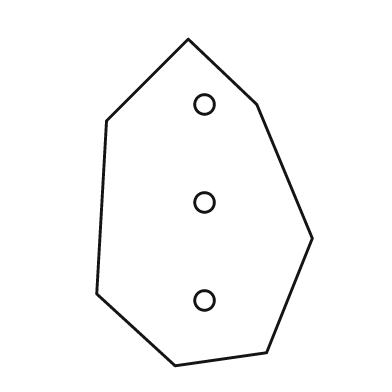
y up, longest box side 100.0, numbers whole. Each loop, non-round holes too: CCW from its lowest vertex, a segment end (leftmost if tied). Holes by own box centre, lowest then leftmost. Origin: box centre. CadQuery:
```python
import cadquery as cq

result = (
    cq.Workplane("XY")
    .moveTo(-9.0, -50.0)
    .lineTo(19.0, -46.0)
    .lineTo(33.0, -11.0)
    .lineTo(16.0, 30.0)
    .lineTo(-5.0, 50.0)
    .lineTo(-30.0, 25.0)
    .lineTo(-33.0, -28.0)
    .close()
    .moveTo(0.0, -30.0)
    .circle(3.0)
    .moveTo(0.0, 0.0)
    .circle(3.0)
    .moveTo(0.0, 30.0)
    .circle(3.0)
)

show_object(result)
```